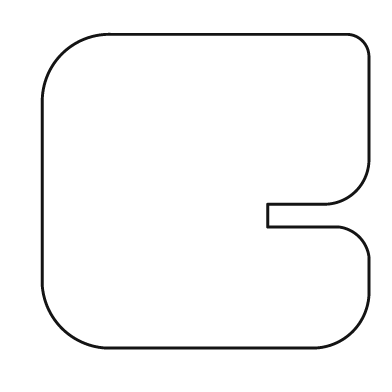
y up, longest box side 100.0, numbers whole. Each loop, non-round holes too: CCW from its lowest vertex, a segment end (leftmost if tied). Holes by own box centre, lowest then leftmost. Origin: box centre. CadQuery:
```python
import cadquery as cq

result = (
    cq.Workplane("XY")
    .moveTo(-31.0, -48.0)
    .lineTo(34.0, -48.0)
    .threePointArc((45.0, -43.0), (50.0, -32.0))
    .lineTo(50.0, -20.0)
    .threePointArc((47.0, -14.0), (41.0, -11.0))
    .lineTo(19.0, -11.0)
    .lineTo(19.0, -4.0)
    .lineTo(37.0, -4.0)
    .threePointArc((46.0, 0.0), (50.0, 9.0))
    .lineTo(50.0, 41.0)
    .threePointArc((48.0, 46.0), (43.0, 48.0))
    .lineTo(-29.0, 48.0)
    .threePointArc((-44.0, 42.0), (-50.0, 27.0))
    .lineTo(-50.0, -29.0)
    .threePointArc((-44.0, -42.0), (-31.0, -48.0))
    .close()
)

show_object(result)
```